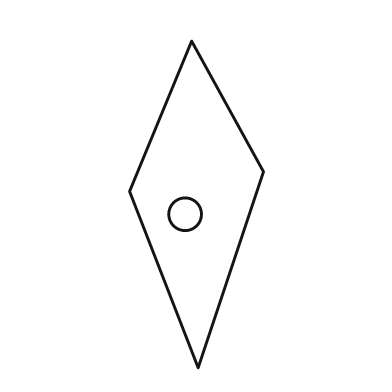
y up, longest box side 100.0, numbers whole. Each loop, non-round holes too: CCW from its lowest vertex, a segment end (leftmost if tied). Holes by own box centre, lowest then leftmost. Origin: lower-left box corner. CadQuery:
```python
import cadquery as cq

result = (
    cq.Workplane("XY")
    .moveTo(21.0, 0.0)
    .lineTo(41.0, 60.0)
    .lineTo(19.0, 100.0)
    .lineTo(0.0, 54.0)
    .close()
    .moveTo(17.0, 47.0)
    .circle(5.0)
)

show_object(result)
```